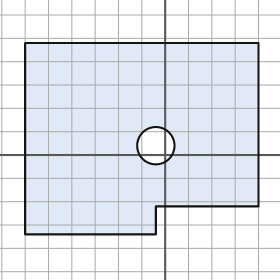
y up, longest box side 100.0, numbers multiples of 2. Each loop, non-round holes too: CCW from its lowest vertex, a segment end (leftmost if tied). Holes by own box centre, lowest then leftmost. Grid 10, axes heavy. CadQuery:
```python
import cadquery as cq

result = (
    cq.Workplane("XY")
    .moveTo(-60.0, -34.0)
    .lineTo(-4.0, -34.0)
    .lineTo(-4.0, -22.0)
    .lineTo(40.0, -22.0)
    .lineTo(40.0, 48.0)
    .lineTo(-60.0, 48.0)
    .close()
    .moveTo(-4.0, 4.0)
    .circle(8.0)
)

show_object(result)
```